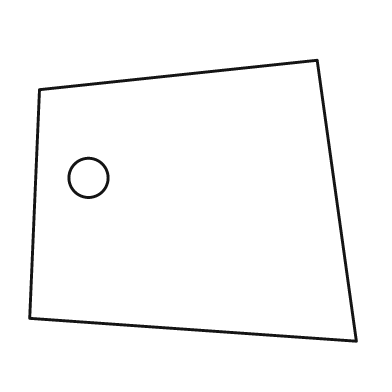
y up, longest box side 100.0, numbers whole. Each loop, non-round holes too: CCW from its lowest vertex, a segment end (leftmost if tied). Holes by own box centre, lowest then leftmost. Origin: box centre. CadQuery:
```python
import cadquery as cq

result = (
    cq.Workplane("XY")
    .moveTo(50.0, -43.0)
    .lineTo(38.0, 43.0)
    .lineTo(-47.0, 34.0)
    .lineTo(-50.0, -36.0)
    .close()
    .moveTo(-32.0, 7.0)
    .circle(6.0)
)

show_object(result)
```